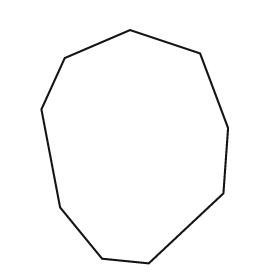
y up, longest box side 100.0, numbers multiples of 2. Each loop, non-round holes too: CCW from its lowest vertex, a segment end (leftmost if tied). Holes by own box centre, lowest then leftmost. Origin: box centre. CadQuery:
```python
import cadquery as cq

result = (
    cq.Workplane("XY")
    .moveTo(6.0, -50.0)
    .lineTo(38.0, -20.0)
    .lineTo(40.0, 8.0)
    .lineTo(28.0, 40.0)
    .lineTo(-2.0, 50.0)
    .lineTo(-30.0, 38.0)
    .lineTo(-40.0, 16.0)
    .lineTo(-32.0, -26.0)
    .lineTo(-14.0, -48.0)
    .close()
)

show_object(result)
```